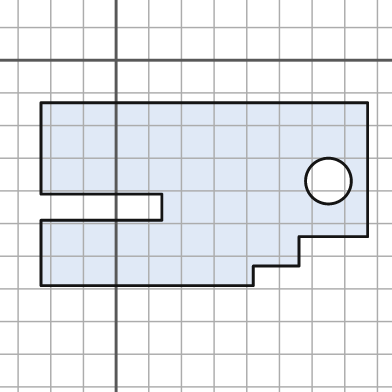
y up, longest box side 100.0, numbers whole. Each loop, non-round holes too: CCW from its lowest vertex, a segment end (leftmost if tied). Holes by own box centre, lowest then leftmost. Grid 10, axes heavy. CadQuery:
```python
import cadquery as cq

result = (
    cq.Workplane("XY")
    .moveTo(-23.0, -69.0)
    .lineTo(42.0, -69.0)
    .lineTo(42.0, -63.0)
    .lineTo(56.0, -63.0)
    .lineTo(56.0, -54.0)
    .lineTo(77.0, -54.0)
    .lineTo(77.0, -13.0)
    .lineTo(-23.0, -13.0)
    .lineTo(-23.0, -41.0)
    .lineTo(14.0, -41.0)
    .lineTo(14.0, -49.0)
    .lineTo(-23.0, -49.0)
    .close()
    .moveTo(65.0, -37.0)
    .circle(7.0)
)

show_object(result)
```